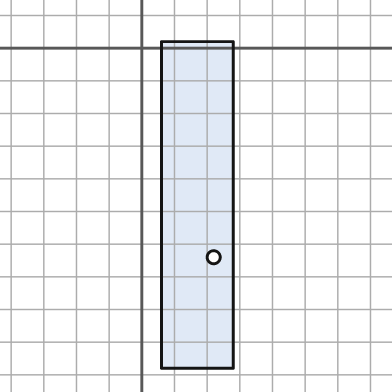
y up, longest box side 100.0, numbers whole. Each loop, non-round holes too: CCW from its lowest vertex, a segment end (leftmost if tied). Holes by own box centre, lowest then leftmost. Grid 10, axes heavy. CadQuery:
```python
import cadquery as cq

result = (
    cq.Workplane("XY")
    .moveTo(6.0, -98.0)
    .lineTo(28.0, -98.0)
    .lineTo(28.0, 2.0)
    .lineTo(6.0, 2.0)
    .close()
    .moveTo(22.0, -64.0)
    .circle(2.0)
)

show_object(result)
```